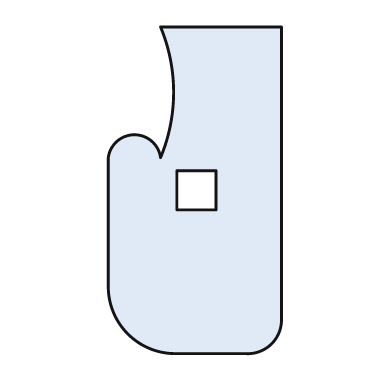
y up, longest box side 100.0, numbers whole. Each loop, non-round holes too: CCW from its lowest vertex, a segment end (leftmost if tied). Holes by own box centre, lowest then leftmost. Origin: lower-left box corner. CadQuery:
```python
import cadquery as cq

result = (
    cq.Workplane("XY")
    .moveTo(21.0, 0.0)
    .lineTo(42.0, 0.0)
    .threePointArc((50.0, 3.0), (53.0, 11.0))
    .lineTo(53.0, 100.0)
    .lineTo(16.0, 100.0)
    .threePointArc((20.0, 80.0), (16.0, 60.0))
    .threePointArc((8.0, 67.0), (0.0, 60.0))
    .lineTo(0.0, 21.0)
    .threePointArc((6.0, 6.0), (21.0, 0.0))
    .close()
    .moveTo(21.0, 44.0)
    .lineTo(33.0, 44.0)
    .lineTo(33.0, 56.0)
    .lineTo(21.0, 56.0)
    .close()
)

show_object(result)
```